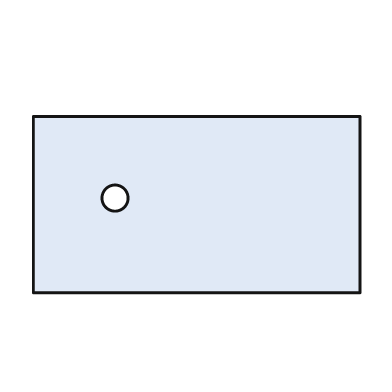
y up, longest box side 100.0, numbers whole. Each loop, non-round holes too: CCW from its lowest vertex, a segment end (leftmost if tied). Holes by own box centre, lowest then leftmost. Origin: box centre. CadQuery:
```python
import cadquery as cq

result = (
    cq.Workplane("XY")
    .moveTo(-50.0, -27.0)
    .lineTo(50.0, -27.0)
    .lineTo(50.0, 27.0)
    .lineTo(-50.0, 27.0)
    .close()
    .moveTo(-25.0, 2.0)
    .circle(4.0)
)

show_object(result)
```